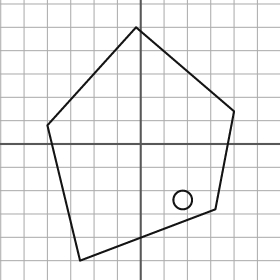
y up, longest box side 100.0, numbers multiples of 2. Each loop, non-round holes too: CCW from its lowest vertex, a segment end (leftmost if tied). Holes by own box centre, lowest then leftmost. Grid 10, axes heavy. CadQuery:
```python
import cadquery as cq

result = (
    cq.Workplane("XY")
    .moveTo(-26.0, -50.0)
    .lineTo(32.0, -28.0)
    .lineTo(40.0, 14.0)
    .lineTo(-2.0, 50.0)
    .lineTo(-40.0, 8.0)
    .close()
    .moveTo(18.0, -24.0)
    .circle(4.0)
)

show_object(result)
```